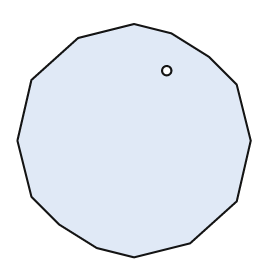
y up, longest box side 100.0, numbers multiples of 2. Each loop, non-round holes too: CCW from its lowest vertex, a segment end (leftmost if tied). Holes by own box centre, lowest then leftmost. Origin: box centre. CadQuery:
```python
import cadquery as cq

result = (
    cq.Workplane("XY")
    .moveTo(0.0, -50.0)
    .lineTo(24.0, -44.0)
    .lineTo(44.0, -26.0)
    .lineTo(50.0, 0.0)
    .lineTo(44.0, 24.0)
    .lineTo(32.0, 36.0)
    .lineTo(16.0, 46.0)
    .lineTo(0.0, 50.0)
    .lineTo(-24.0, 44.0)
    .lineTo(-44.0, 26.0)
    .lineTo(-50.0, 0.0)
    .lineTo(-44.0, -24.0)
    .lineTo(-32.0, -36.0)
    .lineTo(-16.0, -46.0)
    .close()
    .moveTo(14.0, 30.0)
    .circle(2.0)
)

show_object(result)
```